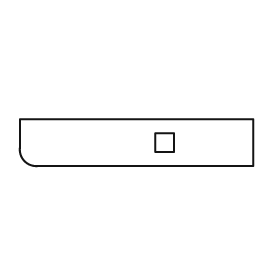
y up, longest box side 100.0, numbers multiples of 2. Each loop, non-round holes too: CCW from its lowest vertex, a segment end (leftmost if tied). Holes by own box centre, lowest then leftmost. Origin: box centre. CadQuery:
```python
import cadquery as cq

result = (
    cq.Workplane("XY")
    .moveTo(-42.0, -10.0)
    .lineTo(50.0, -10.0)
    .lineTo(50.0, 10.0)
    .lineTo(-50.0, 10.0)
    .lineTo(-50.0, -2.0)
    .threePointArc((-48.0, -8.0), (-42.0, -10.0))
    .close()
    .moveTo(8.0, -4.0)
    .lineTo(16.0, -4.0)
    .lineTo(16.0, 4.0)
    .lineTo(8.0, 4.0)
    .close()
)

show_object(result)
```